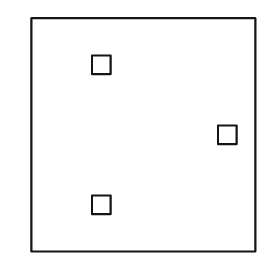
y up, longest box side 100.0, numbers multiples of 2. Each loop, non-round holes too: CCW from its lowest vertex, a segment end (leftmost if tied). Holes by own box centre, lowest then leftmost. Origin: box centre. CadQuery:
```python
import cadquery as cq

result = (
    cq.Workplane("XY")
    .moveTo(-48.0, -50.0)
    .lineTo(48.0, -50.0)
    .lineTo(48.0, 50.0)
    .lineTo(-48.0, 50.0)
    .close()
    .moveTo(-22.0, -34.0)
    .lineTo(-14.0, -34.0)
    .lineTo(-14.0, -26.0)
    .lineTo(-22.0, -26.0)
    .close()
    .moveTo(32.0, -4.0)
    .lineTo(40.0, -4.0)
    .lineTo(40.0, 4.0)
    .lineTo(32.0, 4.0)
    .close()
    .moveTo(-22.0, 26.0)
    .lineTo(-14.0, 26.0)
    .lineTo(-14.0, 34.0)
    .lineTo(-22.0, 34.0)
    .close()
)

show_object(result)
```